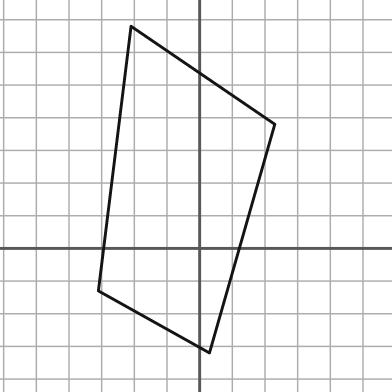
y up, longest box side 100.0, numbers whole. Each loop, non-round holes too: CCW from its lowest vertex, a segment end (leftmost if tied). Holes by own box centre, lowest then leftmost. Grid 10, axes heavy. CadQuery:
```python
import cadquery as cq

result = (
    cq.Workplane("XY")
    .moveTo(3.0, -32.0)
    .lineTo(23.0, 38.0)
    .lineTo(-21.0, 68.0)
    .lineTo(-31.0, -13.0)
    .close()
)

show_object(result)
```